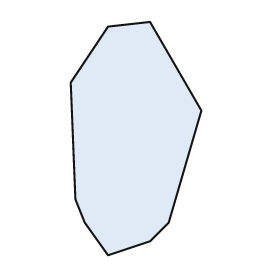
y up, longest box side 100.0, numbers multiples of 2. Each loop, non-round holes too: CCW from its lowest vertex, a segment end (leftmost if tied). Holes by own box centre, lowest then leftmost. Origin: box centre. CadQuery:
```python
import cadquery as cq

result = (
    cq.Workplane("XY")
    .moveTo(-12.0, -50.0)
    .lineTo(6.0, -44.0)
    .lineTo(14.0, -36.0)
    .lineTo(28.0, 12.0)
    .lineTo(6.0, 50.0)
    .lineTo(-12.0, 48.0)
    .lineTo(-28.0, 24.0)
    .lineTo(-26.0, -26.0)
    .lineTo(-22.0, -36.0)
    .close()
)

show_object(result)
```